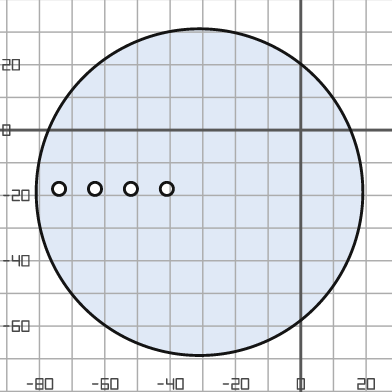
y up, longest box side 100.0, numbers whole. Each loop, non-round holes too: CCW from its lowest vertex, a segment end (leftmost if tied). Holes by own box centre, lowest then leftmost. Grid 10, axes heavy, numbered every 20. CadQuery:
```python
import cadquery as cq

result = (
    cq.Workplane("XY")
    .moveTo(-31.0, -19.0)
    .circle(50.0)
    .moveTo(-74.0, -18.0)
    .circle(2.0)
    .moveTo(-63.0, -18.0)
    .circle(2.0)
    .moveTo(-52.0, -18.0)
    .circle(2.0)
    .moveTo(-41.0, -18.0)
    .circle(2.0)
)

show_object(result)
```